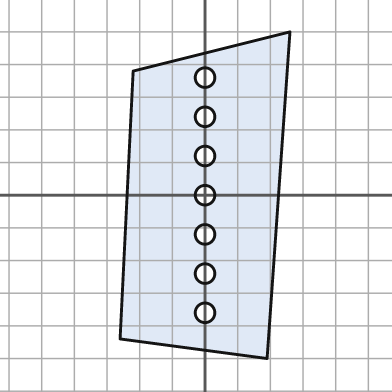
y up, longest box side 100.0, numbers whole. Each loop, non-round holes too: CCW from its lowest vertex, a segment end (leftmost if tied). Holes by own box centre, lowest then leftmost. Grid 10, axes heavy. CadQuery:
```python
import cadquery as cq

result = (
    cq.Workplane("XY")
    .moveTo(19.0, -50.0)
    .lineTo(26.0, 50.0)
    .lineTo(-22.0, 38.0)
    .lineTo(-26.0, -44.0)
    .close()
    .moveTo(0.0, -36.0)
    .circle(3.0)
    .moveTo(0.0, -24.0)
    .circle(3.0)
    .moveTo(0.0, -12.0)
    .circle(3.0)
    .moveTo(0.0, 0.0)
    .circle(3.0)
    .moveTo(0.0, 12.0)
    .circle(3.0)
    .moveTo(0.0, 24.0)
    .circle(3.0)
    .moveTo(0.0, 36.0)
    .circle(3.0)
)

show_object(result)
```